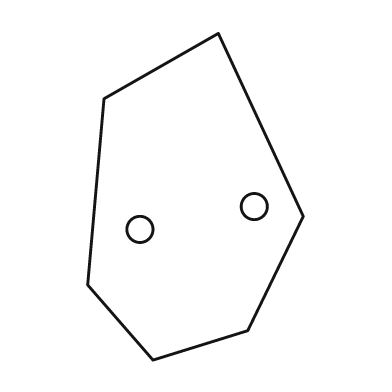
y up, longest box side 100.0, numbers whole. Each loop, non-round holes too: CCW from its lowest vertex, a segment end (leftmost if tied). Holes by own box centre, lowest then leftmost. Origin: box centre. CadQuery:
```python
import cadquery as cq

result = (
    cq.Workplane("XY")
    .moveTo(-13.0, -50.0)
    .lineTo(16.0, -41.0)
    .lineTo(33.0, -6.0)
    .lineTo(7.0, 50.0)
    .lineTo(-28.0, 30.0)
    .lineTo(-33.0, -27.0)
    .close()
    .moveTo(-17.0, -10.0)
    .circle(4.0)
    .moveTo(18.0, -3.0)
    .circle(4.0)
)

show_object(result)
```